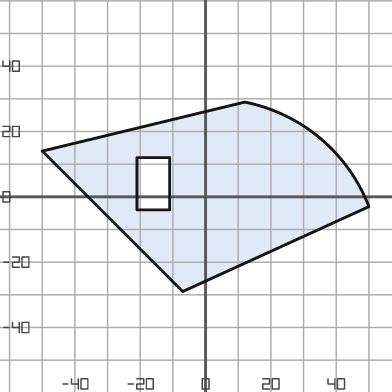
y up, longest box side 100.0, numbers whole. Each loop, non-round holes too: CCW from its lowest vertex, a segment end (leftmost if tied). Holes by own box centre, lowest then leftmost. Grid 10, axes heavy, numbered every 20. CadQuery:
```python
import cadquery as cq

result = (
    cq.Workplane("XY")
    .moveTo(-7.0, -29.0)
    .lineTo(50.0, -3.0)
    .threePointArc((35.0, 18.0), (12.0, 29.0))
    .lineTo(-50.0, 14.0)
    .close()
    .moveTo(-21.0, -4.0)
    .lineTo(-11.0, -4.0)
    .lineTo(-11.0, 12.0)
    .lineTo(-21.0, 12.0)
    .close()
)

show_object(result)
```